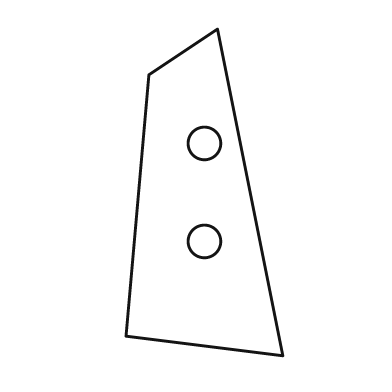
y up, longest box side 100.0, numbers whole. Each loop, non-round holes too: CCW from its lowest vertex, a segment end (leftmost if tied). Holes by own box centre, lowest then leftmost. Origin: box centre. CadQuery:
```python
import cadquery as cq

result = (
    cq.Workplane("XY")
    .moveTo(24.0, -50.0)
    .lineTo(4.0, 50.0)
    .lineTo(-17.0, 36.0)
    .lineTo(-24.0, -44.0)
    .close()
    .moveTo(0.0, -15.0)
    .circle(5.0)
    .moveTo(0.0, 15.0)
    .circle(5.0)
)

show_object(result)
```